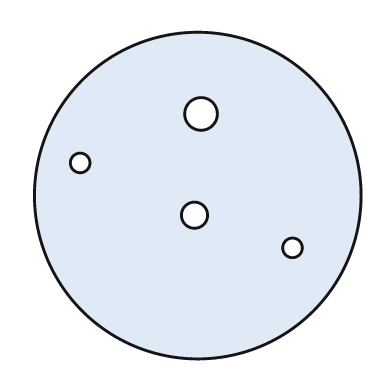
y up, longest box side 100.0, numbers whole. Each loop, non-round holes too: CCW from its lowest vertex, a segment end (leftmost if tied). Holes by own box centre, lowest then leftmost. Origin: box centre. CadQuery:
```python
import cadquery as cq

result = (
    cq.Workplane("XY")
    .moveTo(0.0, 0.0)
    .circle(50.0)
    .moveTo(29.0, -16.0)
    .circle(3.0)
    .moveTo(-1.0, -6.0)
    .circle(4.0)
    .moveTo(-36.0, 10.0)
    .circle(3.0)
    .moveTo(1.0, 25.0)
    .circle(5.0)
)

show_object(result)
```